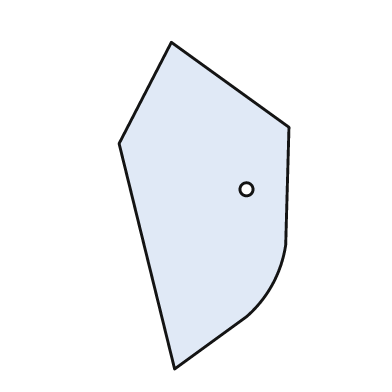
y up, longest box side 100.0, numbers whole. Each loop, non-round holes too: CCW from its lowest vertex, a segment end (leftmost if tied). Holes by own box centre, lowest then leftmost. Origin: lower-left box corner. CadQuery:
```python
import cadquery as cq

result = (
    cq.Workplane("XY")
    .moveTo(17.0, 0.0)
    .lineTo(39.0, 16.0)
    .threePointArc((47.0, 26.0), (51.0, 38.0))
    .lineTo(52.0, 74.0)
    .lineTo(16.0, 100.0)
    .lineTo(0.0, 69.0)
    .close()
    .moveTo(39.0, 55.0)
    .circle(2.0)
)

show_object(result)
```